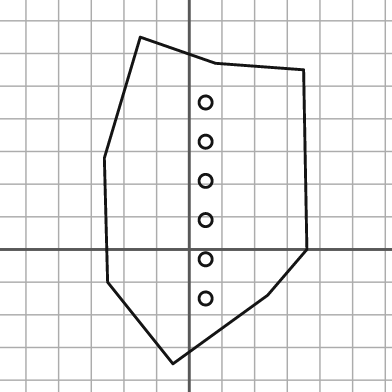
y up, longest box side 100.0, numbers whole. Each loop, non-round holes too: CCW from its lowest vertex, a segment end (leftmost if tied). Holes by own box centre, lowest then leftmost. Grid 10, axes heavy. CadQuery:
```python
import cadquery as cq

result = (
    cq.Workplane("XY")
    .moveTo(-5.0, -35.0)
    .lineTo(24.0, -14.0)
    .lineTo(36.0, 0.0)
    .lineTo(35.0, 55.0)
    .lineTo(8.0, 57.0)
    .lineTo(-15.0, 65.0)
    .lineTo(-26.0, 28.0)
    .lineTo(-25.0, -10.0)
    .close()
    .moveTo(5.0, -15.0)
    .circle(2.0)
    .moveTo(5.0, -3.0)
    .circle(2.0)
    .moveTo(5.0, 9.0)
    .circle(2.0)
    .moveTo(5.0, 21.0)
    .circle(2.0)
    .moveTo(5.0, 33.0)
    .circle(2.0)
    .moveTo(5.0, 45.0)
    .circle(2.0)
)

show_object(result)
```